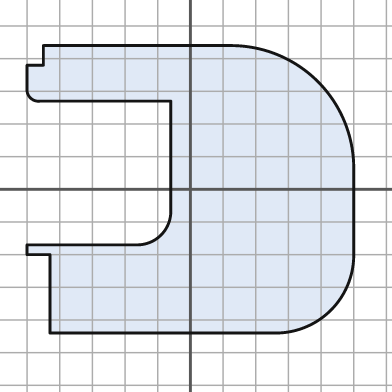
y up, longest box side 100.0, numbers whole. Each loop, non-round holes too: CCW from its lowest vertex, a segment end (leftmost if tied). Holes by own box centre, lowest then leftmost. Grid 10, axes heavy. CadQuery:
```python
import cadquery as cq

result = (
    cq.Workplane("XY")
    .moveTo(-43.0, -44.0)
    .lineTo(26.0, -44.0)
    .threePointArc((43.0, -37.0), (50.0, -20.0))
    .lineTo(50.0, 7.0)
    .threePointArc((39.0, 33.0), (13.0, 44.0))
    .lineTo(-45.0, 44.0)
    .lineTo(-45.0, 38.0)
    .lineTo(-50.0, 38.0)
    .lineTo(-50.0, 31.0)
    .threePointArc((-49.0, 28.0), (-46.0, 27.0))
    .lineTo(-6.0, 27.0)
    .lineTo(-6.0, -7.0)
    .threePointArc((-9.0, -14.0), (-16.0, -17.0))
    .lineTo(-50.0, -17.0)
    .lineTo(-50.0, -20.0)
    .lineTo(-43.0, -20.0)
    .close()
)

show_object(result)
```